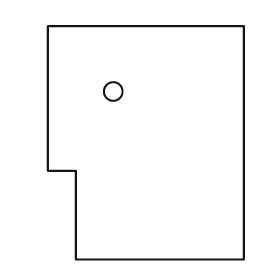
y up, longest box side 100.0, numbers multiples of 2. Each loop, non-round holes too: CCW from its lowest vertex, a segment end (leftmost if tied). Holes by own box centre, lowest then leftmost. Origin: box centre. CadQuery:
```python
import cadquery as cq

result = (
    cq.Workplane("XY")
    .moveTo(-30.0, -50.0)
    .lineTo(42.0, -50.0)
    .lineTo(42.0, 50.0)
    .lineTo(-42.0, 50.0)
    .lineTo(-42.0, -12.0)
    .lineTo(-30.0, -12.0)
    .close()
    .moveTo(-14.0, 22.0)
    .circle(4.0)
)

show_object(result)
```